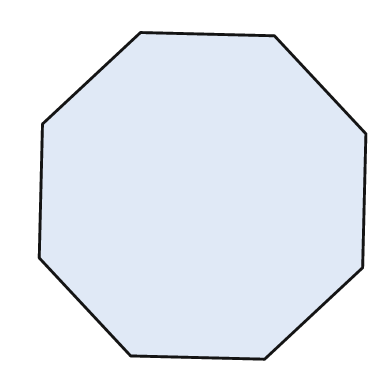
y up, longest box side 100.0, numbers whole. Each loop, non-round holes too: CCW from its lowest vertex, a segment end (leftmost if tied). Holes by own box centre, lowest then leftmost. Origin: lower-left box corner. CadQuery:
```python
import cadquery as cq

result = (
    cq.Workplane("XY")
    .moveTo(69.0, 0.0)
    .lineTo(99.0, 28.0)
    .lineTo(100.0, 69.0)
    .lineTo(72.0, 99.0)
    .lineTo(31.0, 100.0)
    .lineTo(1.0, 72.0)
    .lineTo(0.0, 31.0)
    .lineTo(28.0, 1.0)
    .close()
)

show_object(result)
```